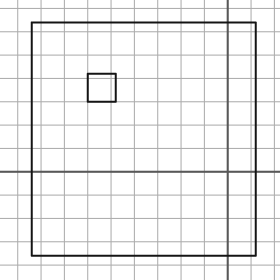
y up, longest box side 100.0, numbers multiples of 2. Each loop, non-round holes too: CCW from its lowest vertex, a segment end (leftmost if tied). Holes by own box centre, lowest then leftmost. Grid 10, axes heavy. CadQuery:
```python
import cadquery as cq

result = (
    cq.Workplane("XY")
    .moveTo(-84.0, -36.0)
    .lineTo(12.0, -36.0)
    .lineTo(12.0, 64.0)
    .lineTo(-84.0, 64.0)
    .close()
    .moveTo(-60.0, 30.0)
    .lineTo(-48.0, 30.0)
    .lineTo(-48.0, 42.0)
    .lineTo(-60.0, 42.0)
    .close()
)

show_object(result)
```